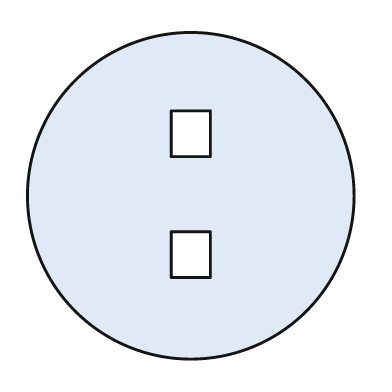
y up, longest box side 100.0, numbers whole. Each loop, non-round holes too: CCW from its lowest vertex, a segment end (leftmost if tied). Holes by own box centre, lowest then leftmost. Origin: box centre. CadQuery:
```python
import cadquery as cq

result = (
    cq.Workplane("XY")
    .moveTo(0.0, 0.0)
    .circle(50.0)
    .moveTo(-6.0, -25.0)
    .lineTo(6.0, -25.0)
    .lineTo(6.0, -11.0)
    .lineTo(-6.0, -11.0)
    .close()
    .moveTo(-6.0, 12.0)
    .lineTo(6.0, 12.0)
    .lineTo(6.0, 26.0)
    .lineTo(-6.0, 26.0)
    .close()
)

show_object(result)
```